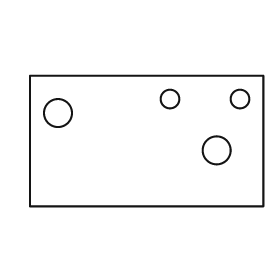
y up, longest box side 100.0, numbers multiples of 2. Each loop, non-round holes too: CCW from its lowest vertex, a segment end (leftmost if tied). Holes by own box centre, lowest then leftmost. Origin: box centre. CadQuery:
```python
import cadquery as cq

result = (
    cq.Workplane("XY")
    .moveTo(-50.0, -28.0)
    .lineTo(50.0, -28.0)
    .lineTo(50.0, 28.0)
    .lineTo(-50.0, 28.0)
    .close()
    .moveTo(30.0, -4.0)
    .circle(6.0)
    .moveTo(-38.0, 12.0)
    .circle(6.0)
    .moveTo(10.0, 18.0)
    .circle(4.0)
    .moveTo(40.0, 18.0)
    .circle(4.0)
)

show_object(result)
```